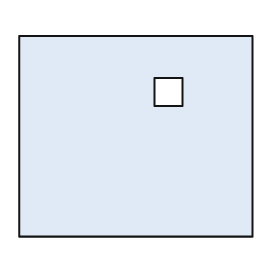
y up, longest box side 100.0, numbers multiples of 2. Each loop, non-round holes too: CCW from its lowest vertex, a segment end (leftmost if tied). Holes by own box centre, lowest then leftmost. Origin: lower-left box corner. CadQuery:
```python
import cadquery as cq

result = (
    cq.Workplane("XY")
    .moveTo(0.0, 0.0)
    .lineTo(100.0, 0.0)
    .lineTo(100.0, 86.0)
    .lineTo(0.0, 86.0)
    .close()
    .moveTo(58.0, 56.0)
    .lineTo(70.0, 56.0)
    .lineTo(70.0, 68.0)
    .lineTo(58.0, 68.0)
    .close()
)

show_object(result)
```